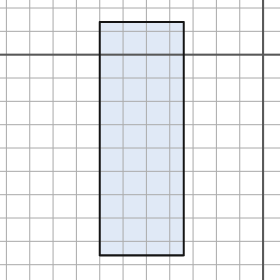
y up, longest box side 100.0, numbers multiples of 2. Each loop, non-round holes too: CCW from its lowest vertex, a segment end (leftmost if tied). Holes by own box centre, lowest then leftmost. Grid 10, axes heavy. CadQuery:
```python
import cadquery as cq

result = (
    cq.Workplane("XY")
    .moveTo(-70.0, -86.0)
    .lineTo(-34.0, -86.0)
    .lineTo(-34.0, 14.0)
    .lineTo(-70.0, 14.0)
    .close()
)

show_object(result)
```